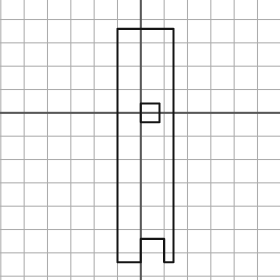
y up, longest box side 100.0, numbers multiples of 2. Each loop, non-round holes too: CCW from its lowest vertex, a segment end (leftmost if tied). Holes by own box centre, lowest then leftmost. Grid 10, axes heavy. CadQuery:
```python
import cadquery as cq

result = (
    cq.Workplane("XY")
    .moveTo(-10.0, -64.0)
    .lineTo(0.0, -64.0)
    .lineTo(0.0, -54.0)
    .lineTo(10.0, -54.0)
    .lineTo(10.0, -64.0)
    .lineTo(14.0, -64.0)
    .lineTo(14.0, 36.0)
    .lineTo(-10.0, 36.0)
    .close()
    .moveTo(0.0, -4.0)
    .lineTo(8.0, -4.0)
    .lineTo(8.0, 4.0)
    .lineTo(0.0, 4.0)
    .close()
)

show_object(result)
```